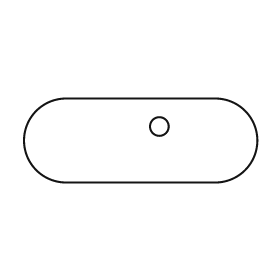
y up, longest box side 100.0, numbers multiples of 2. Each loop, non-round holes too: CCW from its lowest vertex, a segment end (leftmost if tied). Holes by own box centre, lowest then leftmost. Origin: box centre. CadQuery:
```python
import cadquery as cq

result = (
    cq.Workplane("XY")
    .moveTo(-32.0, -18.0)
    .lineTo(32.0, -18.0)
    .threePointArc((50.0, 0.0), (32.0, 18.0))
    .lineTo(-32.0, 18.0)
    .threePointArc((-50.0, 0.0), (-32.0, -18.0))
    .close()
    .moveTo(8.0, 6.0)
    .circle(4.0)
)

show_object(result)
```